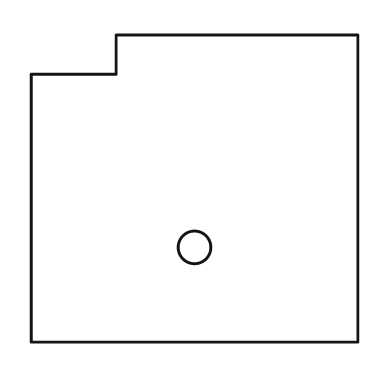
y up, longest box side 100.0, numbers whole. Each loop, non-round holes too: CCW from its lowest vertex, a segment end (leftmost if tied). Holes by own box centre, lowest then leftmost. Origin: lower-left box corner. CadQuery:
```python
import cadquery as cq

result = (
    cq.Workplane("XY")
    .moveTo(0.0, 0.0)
    .lineTo(100.0, 0.0)
    .lineTo(100.0, 94.0)
    .lineTo(26.0, 94.0)
    .lineTo(26.0, 82.0)
    .lineTo(0.0, 82.0)
    .close()
    .moveTo(50.0, 29.0)
    .circle(5.0)
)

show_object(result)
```